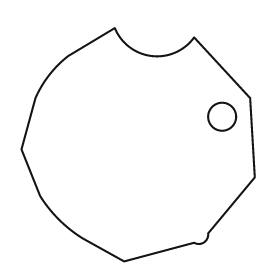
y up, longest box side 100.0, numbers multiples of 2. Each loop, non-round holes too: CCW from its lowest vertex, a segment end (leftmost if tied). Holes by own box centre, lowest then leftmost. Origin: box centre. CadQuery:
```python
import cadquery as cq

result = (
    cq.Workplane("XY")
    .moveTo(-6.0, -50.0)
    .lineTo(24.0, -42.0)
    .threePointArc((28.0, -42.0), (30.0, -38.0))
    .lineTo(50.0, -14.0)
    .lineTo(48.0, 20.0)
    .lineTo(24.0, 46.0)
    .threePointArc((6.0, 38.0), (-10.0, 50.0))
    .lineTo(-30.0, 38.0)
    .threePointArc((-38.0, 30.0), (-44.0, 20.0))
    .lineTo(-50.0, -2.0)
    .lineTo(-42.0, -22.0)
    .threePointArc((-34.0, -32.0), (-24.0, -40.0))
    .close()
    .moveTo(36.0, 12.0)
    .circle(6.0)
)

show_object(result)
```